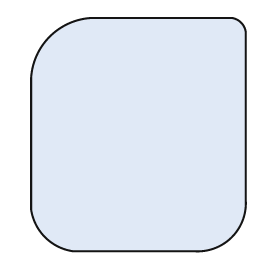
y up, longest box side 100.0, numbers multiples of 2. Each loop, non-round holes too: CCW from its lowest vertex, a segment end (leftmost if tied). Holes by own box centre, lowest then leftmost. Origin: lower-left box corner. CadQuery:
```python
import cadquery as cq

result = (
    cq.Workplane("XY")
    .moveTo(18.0, 0.0)
    .lineTo(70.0, 0.0)
    .threePointArc((86.0, 6.0), (92.0, 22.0))
    .lineTo(92.0, 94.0)
    .threePointArc((90.0, 98.0), (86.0, 100.0))
    .lineTo(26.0, 100.0)
    .threePointArc((8.0, 92.0), (0.0, 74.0))
    .lineTo(0.0, 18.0)
    .threePointArc((6.0, 6.0), (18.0, 0.0))
    .close()
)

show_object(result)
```